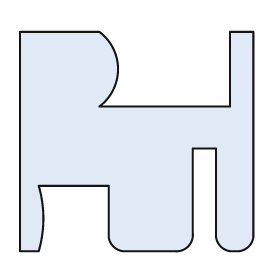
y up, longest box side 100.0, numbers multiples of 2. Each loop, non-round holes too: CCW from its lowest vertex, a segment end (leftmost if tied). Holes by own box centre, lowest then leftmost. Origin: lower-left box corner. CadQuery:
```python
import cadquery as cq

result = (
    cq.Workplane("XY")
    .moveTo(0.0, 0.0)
    .lineTo(8.0, 0.0)
    .threePointArc((10.0, 14.0), (8.0, 28.0))
    .lineTo(38.0, 28.0)
    .lineTo(38.0, 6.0)
    .threePointArc((40.0, 2.0), (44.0, 0.0))
    .lineTo(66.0, 0.0)
    .threePointArc((72.0, 2.0), (74.0, 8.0))
    .lineTo(74.0, 44.0)
    .lineTo(84.0, 44.0)
    .lineTo(84.0, 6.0)
    .threePointArc((86.0, 2.0), (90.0, 0.0))
    .lineTo(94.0, 0.0)
    .threePointArc((98.0, 2.0), (100.0, 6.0))
    .lineTo(100.0, 94.0)
    .lineTo(90.0, 94.0)
    .lineTo(90.0, 62.0)
    .lineTo(34.0, 62.0)
    .threePointArc((42.0, 78.0), (34.0, 94.0))
    .lineTo(0.0, 94.0)
    .close()
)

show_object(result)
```